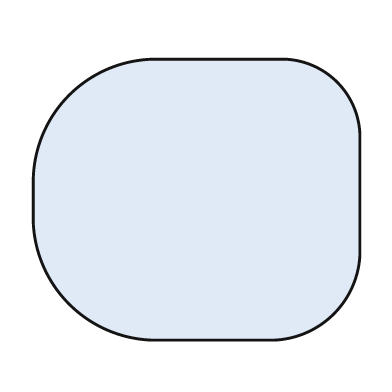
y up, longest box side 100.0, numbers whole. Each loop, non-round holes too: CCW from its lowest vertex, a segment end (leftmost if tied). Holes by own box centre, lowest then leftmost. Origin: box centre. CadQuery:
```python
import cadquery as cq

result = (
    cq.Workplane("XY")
    .moveTo(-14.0, -43.0)
    .lineTo(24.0, -43.0)
    .threePointArc((42.0, -35.0), (50.0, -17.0))
    .lineTo(50.0, 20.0)
    .threePointArc((43.0, 36.0), (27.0, 43.0))
    .lineTo(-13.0, 43.0)
    .threePointArc((-39.0, 32.0), (-50.0, 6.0))
    .lineTo(-50.0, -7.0)
    .threePointArc((-39.0, -32.0), (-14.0, -43.0))
    .close()
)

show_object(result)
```